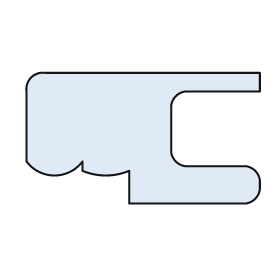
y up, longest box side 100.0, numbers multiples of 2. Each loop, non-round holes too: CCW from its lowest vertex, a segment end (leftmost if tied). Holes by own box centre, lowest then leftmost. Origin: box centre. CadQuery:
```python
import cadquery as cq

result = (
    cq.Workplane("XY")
    .moveTo(-6.0, -28.0)
    .lineTo(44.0, -28.0)
    .threePointArc((48.0, -26.0), (50.0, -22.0))
    .lineTo(50.0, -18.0)
    .threePointArc((48.0, -14.0), (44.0, -12.0))
    .lineTo(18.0, -12.0)
    .threePointArc((14.0, -10.0), (12.0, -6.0))
    .lineTo(12.0, 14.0)
    .threePointArc((14.0, 18.0), (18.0, 20.0))
    .lineTo(50.0, 20.0)
    .lineTo(50.0, 28.0)
    .lineTo(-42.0, 28.0)
    .threePointArc((-48.0, 26.0), (-50.0, 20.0))
    .lineTo(-50.0, -10.0)
    .threePointArc((-38.0, -16.0), (-26.0, -10.0))
    .lineTo(-26.0, -14.0)
    .threePointArc((-16.0, -16.0), (-6.0, -14.0))
    .close()
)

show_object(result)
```